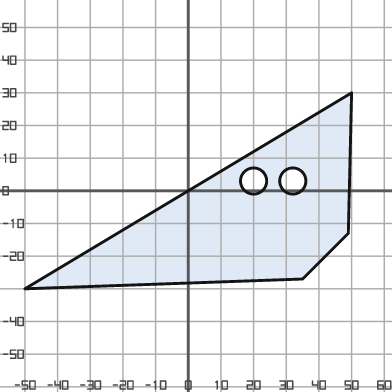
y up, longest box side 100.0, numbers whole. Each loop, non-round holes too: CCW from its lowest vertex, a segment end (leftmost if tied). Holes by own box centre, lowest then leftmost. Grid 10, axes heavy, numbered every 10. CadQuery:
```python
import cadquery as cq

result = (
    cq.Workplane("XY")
    .moveTo(-50.0, -30.0)
    .lineTo(35.0, -27.0)
    .lineTo(49.0, -13.0)
    .lineTo(50.0, 30.0)
    .close()
    .moveTo(20.0, 3.0)
    .circle(4.0)
    .moveTo(32.0, 3.0)
    .circle(4.0)
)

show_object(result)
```